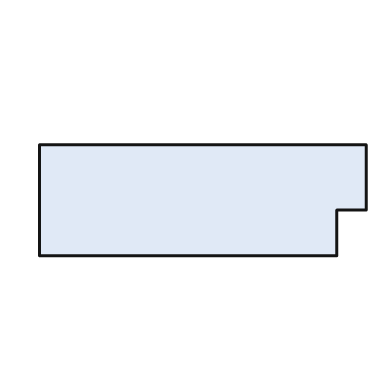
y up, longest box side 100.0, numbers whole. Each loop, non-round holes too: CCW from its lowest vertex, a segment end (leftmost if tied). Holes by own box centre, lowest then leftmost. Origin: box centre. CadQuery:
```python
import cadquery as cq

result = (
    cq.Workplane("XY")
    .moveTo(-50.0, -17.0)
    .lineTo(41.0, -17.0)
    .lineTo(41.0, -3.0)
    .lineTo(50.0, -3.0)
    .lineTo(50.0, 17.0)
    .lineTo(-50.0, 17.0)
    .close()
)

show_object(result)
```